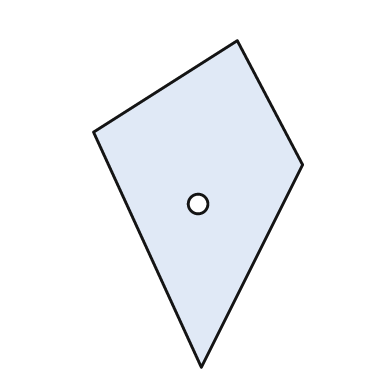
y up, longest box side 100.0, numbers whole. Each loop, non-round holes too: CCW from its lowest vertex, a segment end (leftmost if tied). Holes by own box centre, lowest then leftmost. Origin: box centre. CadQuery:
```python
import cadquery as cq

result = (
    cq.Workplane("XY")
    .moveTo(1.0, -50.0)
    .lineTo(32.0, 12.0)
    .lineTo(12.0, 50.0)
    .lineTo(-32.0, 22.0)
    .close()
    .moveTo(0.0, 0.0)
    .circle(3.0)
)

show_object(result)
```